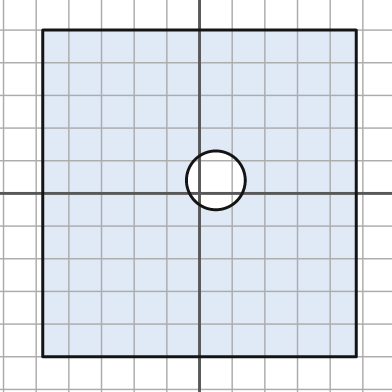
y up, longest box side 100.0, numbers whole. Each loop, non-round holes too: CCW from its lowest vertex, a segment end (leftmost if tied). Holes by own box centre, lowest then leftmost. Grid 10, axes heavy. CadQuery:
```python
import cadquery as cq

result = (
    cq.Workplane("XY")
    .moveTo(-48.0, -50.0)
    .lineTo(48.0, -50.0)
    .lineTo(48.0, 50.0)
    .lineTo(-48.0, 50.0)
    .close()
    .moveTo(5.0, 4.0)
    .circle(9.0)
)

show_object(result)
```